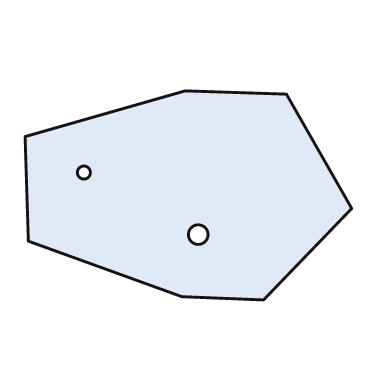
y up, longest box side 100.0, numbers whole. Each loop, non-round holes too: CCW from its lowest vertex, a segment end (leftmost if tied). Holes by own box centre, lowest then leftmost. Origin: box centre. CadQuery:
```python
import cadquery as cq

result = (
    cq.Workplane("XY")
    .moveTo(23.0, -32.0)
    .lineTo(50.0, -4.0)
    .lineTo(30.0, 31.0)
    .lineTo(-1.0, 32.0)
    .lineTo(-50.0, 18.0)
    .lineTo(-49.0, -14.0)
    .lineTo(-2.0, -31.0)
    .close()
    .moveTo(3.0, -12.0)
    .circle(3.0)
    .moveTo(-32.0, 7.0)
    .circle(2.0)
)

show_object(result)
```